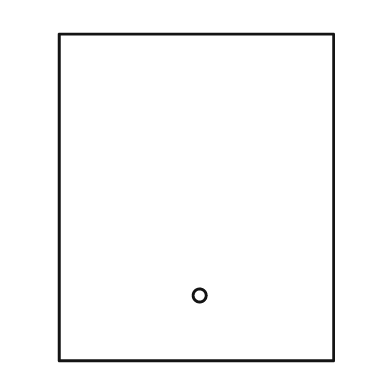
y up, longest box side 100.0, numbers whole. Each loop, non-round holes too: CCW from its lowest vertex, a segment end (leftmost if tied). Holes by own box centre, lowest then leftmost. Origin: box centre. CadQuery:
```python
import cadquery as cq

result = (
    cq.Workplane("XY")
    .moveTo(-42.0, -50.0)
    .lineTo(42.0, -50.0)
    .lineTo(42.0, 50.0)
    .lineTo(-42.0, 50.0)
    .close()
    .moveTo(1.0, -30.0)
    .circle(2.0)
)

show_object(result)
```